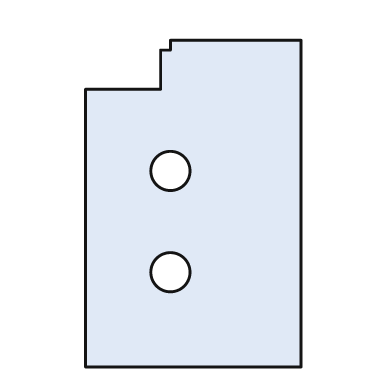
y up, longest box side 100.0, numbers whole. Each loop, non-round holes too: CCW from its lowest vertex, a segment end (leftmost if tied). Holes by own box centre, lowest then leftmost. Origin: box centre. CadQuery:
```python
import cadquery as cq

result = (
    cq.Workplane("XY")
    .moveTo(-33.0, -50.0)
    .lineTo(33.0, -50.0)
    .lineTo(33.0, 50.0)
    .lineTo(-7.0, 50.0)
    .lineTo(-7.0, 47.0)
    .lineTo(-10.0, 47.0)
    .lineTo(-10.0, 35.0)
    .lineTo(-33.0, 35.0)
    .close()
    .moveTo(-7.0, -21.0)
    .circle(6.0)
    .moveTo(-7.0, 10.0)
    .circle(6.0)
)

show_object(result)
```